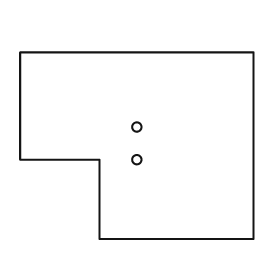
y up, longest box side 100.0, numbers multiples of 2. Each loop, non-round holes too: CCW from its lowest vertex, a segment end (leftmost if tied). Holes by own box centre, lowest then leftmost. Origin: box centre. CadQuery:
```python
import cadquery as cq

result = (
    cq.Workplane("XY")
    .moveTo(-16.0, -40.0)
    .lineTo(50.0, -40.0)
    .lineTo(50.0, 40.0)
    .lineTo(-50.0, 40.0)
    .lineTo(-50.0, -6.0)
    .lineTo(-16.0, -6.0)
    .close()
    .moveTo(0.0, -6.0)
    .circle(2.0)
    .moveTo(0.0, 8.0)
    .circle(2.0)
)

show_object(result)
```